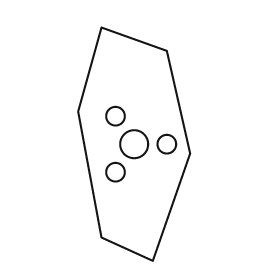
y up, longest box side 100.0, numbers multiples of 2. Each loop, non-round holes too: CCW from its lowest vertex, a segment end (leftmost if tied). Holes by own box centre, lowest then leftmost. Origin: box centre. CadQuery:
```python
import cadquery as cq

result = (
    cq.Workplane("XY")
    .moveTo(8.0, -50.0)
    .lineTo(24.0, -4.0)
    .lineTo(14.0, 40.0)
    .lineTo(-14.0, 50.0)
    .lineTo(-24.0, 14.0)
    .lineTo(-14.0, -40.0)
    .close()
    .moveTo(-8.0, -12.0)
    .circle(4.0)
    .moveTo(0.0, 0.0)
    .circle(6.0)
    .moveTo(14.0, 0.0)
    .circle(4.0)
    .moveTo(-8.0, 12.0)
    .circle(4.0)
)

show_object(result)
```